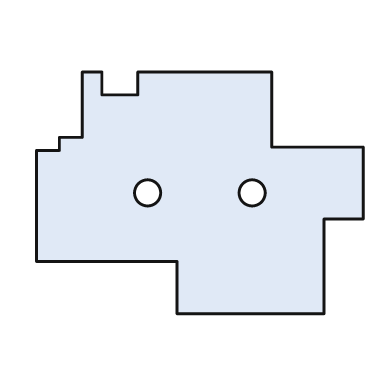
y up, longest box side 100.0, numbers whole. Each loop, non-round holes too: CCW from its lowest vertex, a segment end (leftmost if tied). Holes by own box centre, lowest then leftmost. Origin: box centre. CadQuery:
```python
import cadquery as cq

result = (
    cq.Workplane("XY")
    .moveTo(-7.0, -37.0)
    .lineTo(38.0, -37.0)
    .lineTo(38.0, -8.0)
    .lineTo(50.0, -8.0)
    .lineTo(50.0, 14.0)
    .lineTo(22.0, 14.0)
    .lineTo(22.0, 37.0)
    .lineTo(-19.0, 37.0)
    .lineTo(-19.0, 30.0)
    .lineTo(-30.0, 30.0)
    .lineTo(-30.0, 37.0)
    .lineTo(-36.0, 37.0)
    .lineTo(-36.0, 17.0)
    .lineTo(-43.0, 17.0)
    .lineTo(-43.0, 13.0)
    .lineTo(-50.0, 13.0)
    .lineTo(-50.0, -21.0)
    .lineTo(-7.0, -21.0)
    .close()
    .moveTo(-16.0, 0.0)
    .circle(4.0)
    .moveTo(16.0, 0.0)
    .circle(4.0)
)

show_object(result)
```